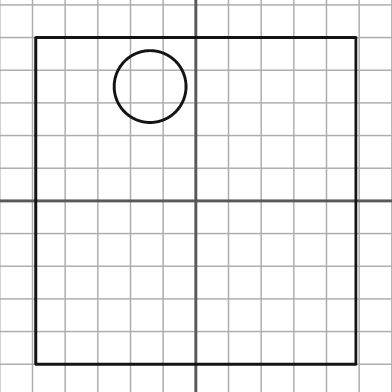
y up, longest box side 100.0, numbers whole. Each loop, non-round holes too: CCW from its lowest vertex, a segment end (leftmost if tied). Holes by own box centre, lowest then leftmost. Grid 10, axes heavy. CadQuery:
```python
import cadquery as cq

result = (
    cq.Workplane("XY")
    .moveTo(-49.0, -50.0)
    .lineTo(49.0, -50.0)
    .lineTo(49.0, 50.0)
    .lineTo(-49.0, 50.0)
    .close()
    .moveTo(-14.0, 35.0)
    .circle(11.0)
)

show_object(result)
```